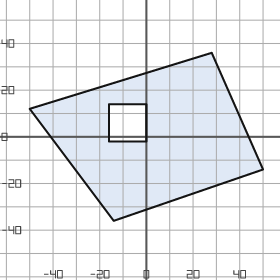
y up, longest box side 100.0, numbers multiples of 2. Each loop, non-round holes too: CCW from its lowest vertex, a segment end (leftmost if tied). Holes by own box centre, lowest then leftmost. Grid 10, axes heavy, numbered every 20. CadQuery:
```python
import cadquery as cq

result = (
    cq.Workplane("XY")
    .moveTo(-14.0, -36.0)
    .lineTo(50.0, -14.0)
    .lineTo(28.0, 36.0)
    .lineTo(-50.0, 12.0)
    .close()
    .moveTo(-16.0, -2.0)
    .lineTo(0.0, -2.0)
    .lineTo(0.0, 14.0)
    .lineTo(-16.0, 14.0)
    .close()
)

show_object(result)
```